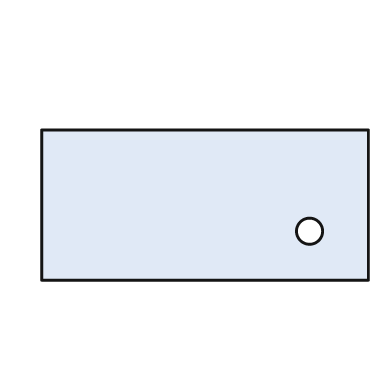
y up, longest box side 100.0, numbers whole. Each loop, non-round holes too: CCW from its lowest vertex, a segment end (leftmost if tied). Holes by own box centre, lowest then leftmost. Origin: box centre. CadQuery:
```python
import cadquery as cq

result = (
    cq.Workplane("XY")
    .moveTo(-50.0, -23.0)
    .lineTo(50.0, -23.0)
    .lineTo(50.0, 23.0)
    .lineTo(-50.0, 23.0)
    .close()
    .moveTo(32.0, -8.0)
    .circle(4.0)
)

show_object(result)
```